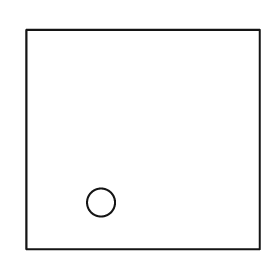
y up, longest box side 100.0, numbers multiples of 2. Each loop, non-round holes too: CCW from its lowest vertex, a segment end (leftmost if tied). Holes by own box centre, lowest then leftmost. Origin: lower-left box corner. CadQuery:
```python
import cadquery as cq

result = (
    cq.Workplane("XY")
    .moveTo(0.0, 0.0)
    .lineTo(100.0, 0.0)
    .lineTo(100.0, 94.0)
    .lineTo(0.0, 94.0)
    .close()
    .moveTo(32.0, 20.0)
    .circle(6.0)
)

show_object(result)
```